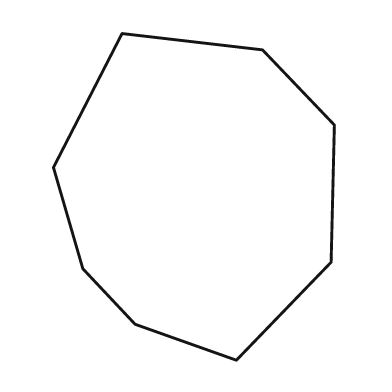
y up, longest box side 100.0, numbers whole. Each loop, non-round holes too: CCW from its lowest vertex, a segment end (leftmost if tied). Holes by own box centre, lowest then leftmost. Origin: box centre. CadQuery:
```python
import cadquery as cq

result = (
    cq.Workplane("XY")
    .moveTo(13.0, -50.0)
    .lineTo(42.0, -20.0)
    .lineTo(43.0, 22.0)
    .lineTo(21.0, 45.0)
    .lineTo(-22.0, 50.0)
    .lineTo(-43.0, 9.0)
    .lineTo(-34.0, -22.0)
    .lineTo(-18.0, -39.0)
    .close()
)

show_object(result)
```